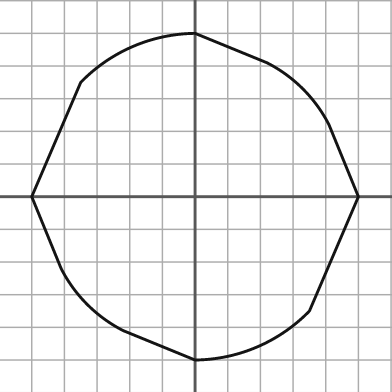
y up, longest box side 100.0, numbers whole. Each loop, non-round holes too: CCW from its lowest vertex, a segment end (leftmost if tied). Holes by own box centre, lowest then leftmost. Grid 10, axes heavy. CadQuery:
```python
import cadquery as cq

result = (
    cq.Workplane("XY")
    .moveTo(0.0, -50.0)
    .threePointArc((19.0, -46.0), (35.0, -35.0))
    .lineTo(50.0, 0.0)
    .lineTo(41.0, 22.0)
    .threePointArc((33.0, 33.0), (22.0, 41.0))
    .lineTo(0.0, 50.0)
    .threePointArc((-19.0, 46.0), (-35.0, 35.0))
    .lineTo(-50.0, 0.0)
    .lineTo(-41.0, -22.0)
    .threePointArc((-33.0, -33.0), (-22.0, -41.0))
    .close()
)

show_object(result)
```